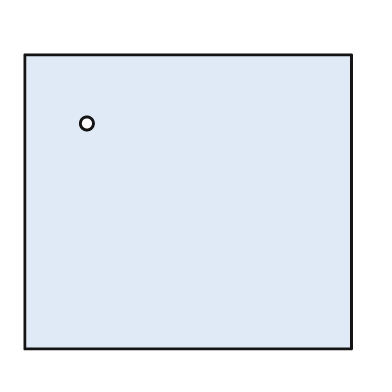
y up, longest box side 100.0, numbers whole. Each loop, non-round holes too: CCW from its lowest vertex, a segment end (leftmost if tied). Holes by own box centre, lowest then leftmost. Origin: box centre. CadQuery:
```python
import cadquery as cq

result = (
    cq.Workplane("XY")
    .moveTo(-50.0, -45.0)
    .lineTo(50.0, -45.0)
    .lineTo(50.0, 45.0)
    .lineTo(-50.0, 45.0)
    .close()
    .moveTo(-31.0, 24.0)
    .circle(2.0)
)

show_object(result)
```